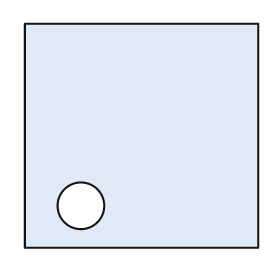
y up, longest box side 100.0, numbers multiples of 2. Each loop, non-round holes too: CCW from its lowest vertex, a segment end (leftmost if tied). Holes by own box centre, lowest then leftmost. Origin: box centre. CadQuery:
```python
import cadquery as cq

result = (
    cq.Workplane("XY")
    .moveTo(-50.0, -48.0)
    .lineTo(50.0, -48.0)
    .lineTo(50.0, 48.0)
    .lineTo(-50.0, 48.0)
    .close()
    .moveTo(-26.0, -30.0)
    .circle(10.0)
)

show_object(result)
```